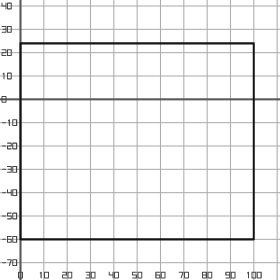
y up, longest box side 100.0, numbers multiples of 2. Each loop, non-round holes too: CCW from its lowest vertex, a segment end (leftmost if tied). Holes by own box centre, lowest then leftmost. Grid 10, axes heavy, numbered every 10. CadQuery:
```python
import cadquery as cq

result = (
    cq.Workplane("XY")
    .moveTo(0.0, -60.0)
    .lineTo(100.0, -60.0)
    .lineTo(100.0, 24.0)
    .lineTo(0.0, 24.0)
    .close()
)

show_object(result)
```